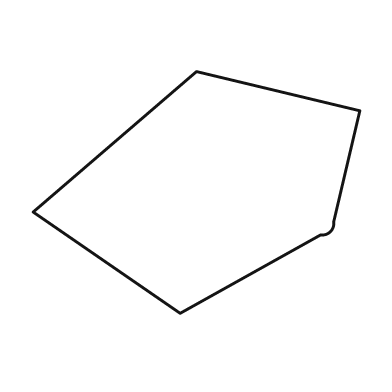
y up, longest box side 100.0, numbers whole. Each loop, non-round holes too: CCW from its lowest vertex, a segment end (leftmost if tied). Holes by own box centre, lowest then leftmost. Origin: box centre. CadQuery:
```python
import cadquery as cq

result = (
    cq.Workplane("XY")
    .moveTo(-5.0, -37.0)
    .lineTo(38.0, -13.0)
    .threePointArc((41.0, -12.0), (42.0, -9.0))
    .lineTo(50.0, 25.0)
    .lineTo(0.0, 37.0)
    .lineTo(-50.0, -6.0)
    .close()
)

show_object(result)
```